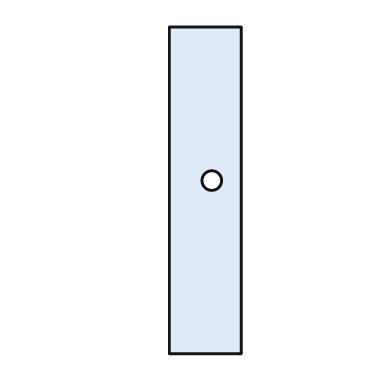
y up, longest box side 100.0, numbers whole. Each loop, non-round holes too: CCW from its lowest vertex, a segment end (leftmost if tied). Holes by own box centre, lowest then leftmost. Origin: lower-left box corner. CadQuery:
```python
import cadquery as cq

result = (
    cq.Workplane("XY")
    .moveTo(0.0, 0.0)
    .lineTo(22.0, 0.0)
    .lineTo(22.0, 100.0)
    .lineTo(0.0, 100.0)
    .close()
    .moveTo(13.0, 53.0)
    .circle(3.0)
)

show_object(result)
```